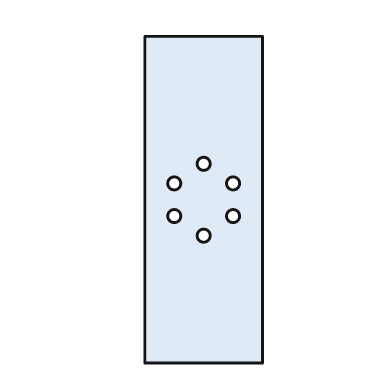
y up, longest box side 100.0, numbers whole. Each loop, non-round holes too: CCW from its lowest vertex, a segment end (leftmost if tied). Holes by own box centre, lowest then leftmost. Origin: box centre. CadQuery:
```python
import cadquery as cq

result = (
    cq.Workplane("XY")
    .moveTo(-18.0, -50.0)
    .lineTo(18.0, -50.0)
    .lineTo(18.0, 50.0)
    .lineTo(-18.0, 50.0)
    .close()
    .moveTo(0.0, -11.0)
    .circle(2.0)
    .moveTo(-9.0, -5.0)
    .circle(2.0)
    .moveTo(9.0, -5.0)
    .circle(2.0)
    .moveTo(-9.0, 5.0)
    .circle(2.0)
    .moveTo(9.0, 5.0)
    .circle(2.0)
    .moveTo(0.0, 11.0)
    .circle(2.0)
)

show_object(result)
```